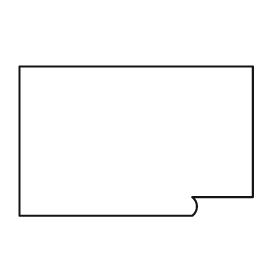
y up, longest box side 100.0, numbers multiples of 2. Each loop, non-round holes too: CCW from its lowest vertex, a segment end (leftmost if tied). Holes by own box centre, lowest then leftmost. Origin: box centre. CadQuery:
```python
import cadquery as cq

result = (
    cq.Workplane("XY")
    .moveTo(-50.0, -32.0)
    .lineTo(24.0, -32.0)
    .threePointArc((26.0, -28.0), (24.0, -24.0))
    .lineTo(50.0, -24.0)
    .lineTo(50.0, 32.0)
    .lineTo(-50.0, 32.0)
    .close()
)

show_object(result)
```